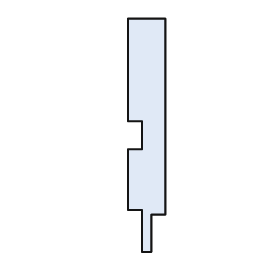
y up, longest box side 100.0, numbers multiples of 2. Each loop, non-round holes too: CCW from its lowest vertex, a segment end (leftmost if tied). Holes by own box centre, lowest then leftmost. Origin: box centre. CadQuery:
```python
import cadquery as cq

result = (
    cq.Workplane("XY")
    .moveTo(-2.0, -50.0)
    .lineTo(2.0, -50.0)
    .lineTo(2.0, -34.0)
    .lineTo(8.0, -34.0)
    .lineTo(8.0, 50.0)
    .lineTo(-8.0, 50.0)
    .lineTo(-8.0, 6.0)
    .lineTo(-2.0, 6.0)
    .lineTo(-2.0, -6.0)
    .lineTo(-8.0, -6.0)
    .lineTo(-8.0, -32.0)
    .lineTo(-2.0, -32.0)
    .close()
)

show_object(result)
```